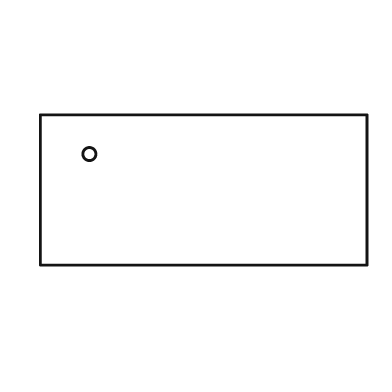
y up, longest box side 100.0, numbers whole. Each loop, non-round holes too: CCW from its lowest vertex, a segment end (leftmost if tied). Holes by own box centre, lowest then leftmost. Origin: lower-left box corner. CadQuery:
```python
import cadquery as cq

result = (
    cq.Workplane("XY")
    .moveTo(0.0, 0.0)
    .lineTo(100.0, 0.0)
    .lineTo(100.0, 46.0)
    .lineTo(0.0, 46.0)
    .close()
    .moveTo(15.0, 34.0)
    .circle(2.0)
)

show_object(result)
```